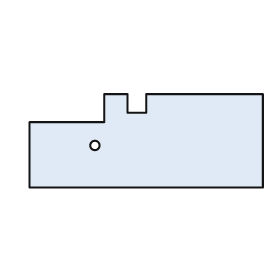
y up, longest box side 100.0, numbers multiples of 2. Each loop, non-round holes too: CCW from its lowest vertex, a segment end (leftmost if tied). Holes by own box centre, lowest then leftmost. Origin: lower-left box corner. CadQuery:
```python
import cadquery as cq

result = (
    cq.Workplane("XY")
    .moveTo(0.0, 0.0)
    .lineTo(100.0, 0.0)
    .lineTo(100.0, 40.0)
    .lineTo(50.0, 40.0)
    .lineTo(50.0, 32.0)
    .lineTo(42.0, 32.0)
    .lineTo(42.0, 40.0)
    .lineTo(32.0, 40.0)
    .lineTo(32.0, 28.0)
    .lineTo(0.0, 28.0)
    .close()
    .moveTo(28.0, 18.0)
    .circle(2.0)
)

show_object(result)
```